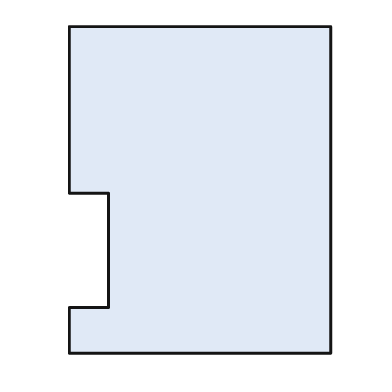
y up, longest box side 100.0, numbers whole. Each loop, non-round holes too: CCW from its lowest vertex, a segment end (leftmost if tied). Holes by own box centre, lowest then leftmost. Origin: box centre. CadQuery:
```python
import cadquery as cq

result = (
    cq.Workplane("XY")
    .moveTo(-40.0, -50.0)
    .lineTo(40.0, -50.0)
    .lineTo(40.0, 50.0)
    .lineTo(-40.0, 50.0)
    .lineTo(-40.0, -1.0)
    .lineTo(-28.0, -1.0)
    .lineTo(-28.0, -36.0)
    .lineTo(-40.0, -36.0)
    .close()
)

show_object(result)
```